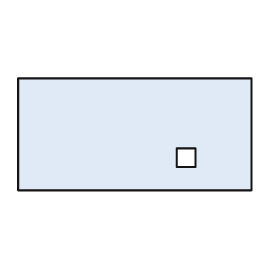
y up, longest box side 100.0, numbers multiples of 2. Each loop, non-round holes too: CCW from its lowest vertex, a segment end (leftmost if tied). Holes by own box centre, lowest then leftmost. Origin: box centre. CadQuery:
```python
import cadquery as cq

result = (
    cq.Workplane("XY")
    .moveTo(-50.0, -24.0)
    .lineTo(50.0, -24.0)
    .lineTo(50.0, 24.0)
    .lineTo(-50.0, 24.0)
    .close()
    .moveTo(18.0, -14.0)
    .lineTo(26.0, -14.0)
    .lineTo(26.0, -6.0)
    .lineTo(18.0, -6.0)
    .close()
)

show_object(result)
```